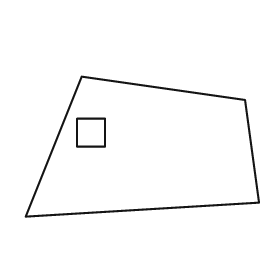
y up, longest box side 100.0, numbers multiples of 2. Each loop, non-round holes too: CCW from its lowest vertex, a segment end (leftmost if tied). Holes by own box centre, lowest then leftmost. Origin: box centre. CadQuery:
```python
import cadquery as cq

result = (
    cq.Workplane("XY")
    .moveTo(-50.0, -30.0)
    .lineTo(50.0, -24.0)
    .lineTo(44.0, 20.0)
    .lineTo(-26.0, 30.0)
    .close()
    .moveTo(-28.0, 0.0)
    .lineTo(-16.0, 0.0)
    .lineTo(-16.0, 12.0)
    .lineTo(-28.0, 12.0)
    .close()
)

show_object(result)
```